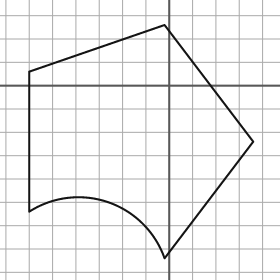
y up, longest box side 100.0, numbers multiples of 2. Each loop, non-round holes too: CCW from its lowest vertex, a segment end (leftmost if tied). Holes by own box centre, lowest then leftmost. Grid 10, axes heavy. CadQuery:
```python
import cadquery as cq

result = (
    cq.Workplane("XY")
    .moveTo(-2.0, -74.0)
    .lineTo(36.0, -24.0)
    .lineTo(-2.0, 26.0)
    .lineTo(-60.0, 6.0)
    .lineTo(-60.0, -54.0)
    .threePointArc((-26.0, -50.0), (-2.0, -74.0))
    .close()
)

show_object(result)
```